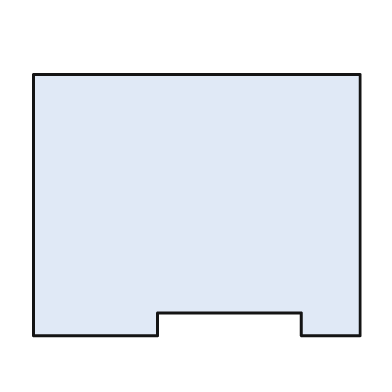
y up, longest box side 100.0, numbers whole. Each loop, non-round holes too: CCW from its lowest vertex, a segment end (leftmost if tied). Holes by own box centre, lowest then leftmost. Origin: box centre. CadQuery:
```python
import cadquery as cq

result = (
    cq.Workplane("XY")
    .moveTo(-50.0, -40.0)
    .lineTo(-12.0, -40.0)
    .lineTo(-12.0, -33.0)
    .lineTo(32.0, -33.0)
    .lineTo(32.0, -40.0)
    .lineTo(50.0, -40.0)
    .lineTo(50.0, 40.0)
    .lineTo(-50.0, 40.0)
    .close()
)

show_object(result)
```